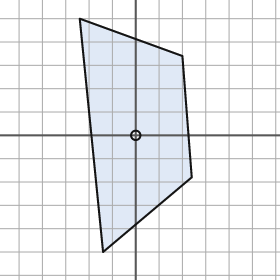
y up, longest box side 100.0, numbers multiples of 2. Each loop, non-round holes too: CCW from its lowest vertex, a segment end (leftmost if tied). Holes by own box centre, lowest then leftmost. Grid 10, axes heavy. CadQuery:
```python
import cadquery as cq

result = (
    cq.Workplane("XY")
    .moveTo(-14.0, -50.0)
    .lineTo(24.0, -18.0)
    .lineTo(20.0, 34.0)
    .lineTo(-24.0, 50.0)
    .close()
    .moveTo(0.0, 0.0)
    .circle(2.0)
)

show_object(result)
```